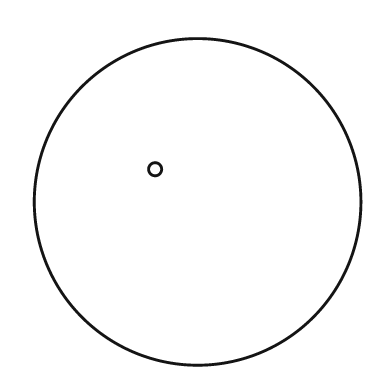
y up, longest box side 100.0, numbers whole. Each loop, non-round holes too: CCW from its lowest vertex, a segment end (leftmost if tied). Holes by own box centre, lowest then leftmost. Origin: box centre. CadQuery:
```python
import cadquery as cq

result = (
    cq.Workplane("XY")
    .moveTo(0.0, 0.0)
    .circle(50.0)
    .moveTo(-13.0, 10.0)
    .circle(2.0)
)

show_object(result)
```